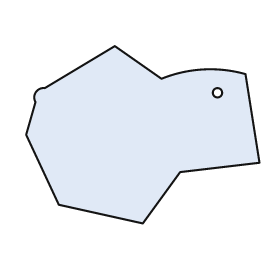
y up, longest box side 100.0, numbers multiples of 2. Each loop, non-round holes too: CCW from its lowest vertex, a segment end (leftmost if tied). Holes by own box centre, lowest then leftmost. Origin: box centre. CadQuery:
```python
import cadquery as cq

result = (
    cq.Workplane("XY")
    .moveTo(0.0, -38.0)
    .lineTo(16.0, -16.0)
    .lineTo(50.0, -12.0)
    .lineTo(44.0, 26.0)
    .threePointArc((26.0, 28.0), (8.0, 24.0))
    .lineTo(-12.0, 38.0)
    .lineTo(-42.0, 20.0)
    .threePointArc((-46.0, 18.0), (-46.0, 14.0))
    .lineTo(-50.0, 0.0)
    .lineTo(-36.0, -30.0)
    .close()
    .moveTo(32.0, 18.0)
    .circle(2.0)
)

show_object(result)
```